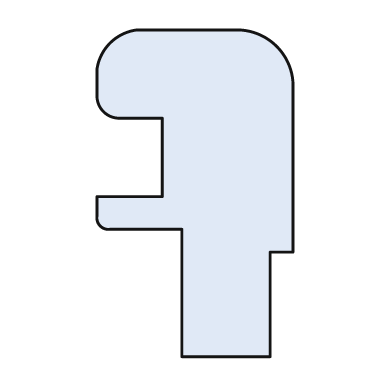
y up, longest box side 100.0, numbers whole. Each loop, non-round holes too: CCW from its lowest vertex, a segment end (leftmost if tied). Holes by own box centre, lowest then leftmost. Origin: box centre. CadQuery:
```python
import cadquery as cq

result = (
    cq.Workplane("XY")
    .moveTo(-4.0, -50.0)
    .lineTo(23.0, -50.0)
    .lineTo(23.0, -18.0)
    .lineTo(30.0, -18.0)
    .lineTo(30.0, 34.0)
    .threePointArc((25.0, 45.0), (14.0, 50.0))
    .lineTo(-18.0, 50.0)
    .threePointArc((-26.0, 46.0), (-30.0, 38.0))
    .lineTo(-30.0, 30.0)
    .threePointArc((-28.0, 25.0), (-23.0, 23.0))
    .lineTo(-10.0, 23.0)
    .lineTo(-10.0, -1.0)
    .lineTo(-30.0, -1.0)
    .lineTo(-30.0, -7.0)
    .threePointArc((-29.0, -10.0), (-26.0, -11.0))
    .lineTo(-4.0, -11.0)
    .close()
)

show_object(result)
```